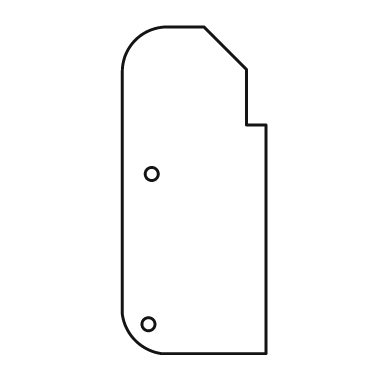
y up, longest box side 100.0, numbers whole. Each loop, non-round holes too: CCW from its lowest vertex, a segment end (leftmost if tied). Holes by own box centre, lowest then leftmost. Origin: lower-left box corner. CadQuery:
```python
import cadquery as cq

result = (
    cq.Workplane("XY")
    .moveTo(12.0, 0.0)
    .lineTo(44.0, 0.0)
    .lineTo(44.0, 70.0)
    .lineTo(38.0, 70.0)
    .lineTo(38.0, 87.0)
    .lineTo(25.0, 100.0)
    .lineTo(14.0, 100.0)
    .threePointArc((4.0, 96.0), (0.0, 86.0))
    .lineTo(0.0, 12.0)
    .threePointArc((4.0, 4.0), (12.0, 0.0))
    .close()
    .moveTo(8.0, 9.0)
    .circle(2.0)
    .moveTo(9.0, 55.0)
    .circle(2.0)
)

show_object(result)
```